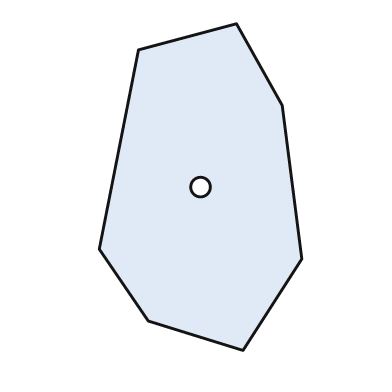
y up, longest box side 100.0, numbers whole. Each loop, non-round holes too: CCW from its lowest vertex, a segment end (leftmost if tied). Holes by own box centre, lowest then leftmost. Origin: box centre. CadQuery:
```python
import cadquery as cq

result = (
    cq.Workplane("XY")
    .moveTo(13.0, -50.0)
    .lineTo(31.0, -22.0)
    .lineTo(25.0, 25.0)
    .lineTo(11.0, 50.0)
    .lineTo(-19.0, 42.0)
    .lineTo(-31.0, -19.0)
    .lineTo(-16.0, -41.0)
    .close()
    .moveTo(0.0, 0.0)
    .circle(3.0)
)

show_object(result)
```